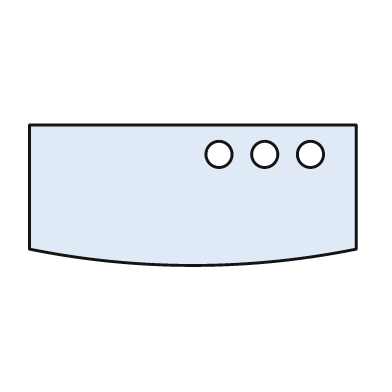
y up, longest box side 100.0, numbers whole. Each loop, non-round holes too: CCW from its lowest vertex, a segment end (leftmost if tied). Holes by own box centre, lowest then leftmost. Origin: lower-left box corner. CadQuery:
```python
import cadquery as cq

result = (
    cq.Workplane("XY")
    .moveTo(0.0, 5.0)
    .threePointArc((50.0, 0.0), (100.0, 5.0))
    .lineTo(100.0, 43.0)
    .lineTo(0.0, 43.0)
    .close()
    .moveTo(58.0, 34.0)
    .circle(4.0)
    .moveTo(72.0, 34.0)
    .circle(4.0)
    .moveTo(86.0, 34.0)
    .circle(4.0)
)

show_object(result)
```